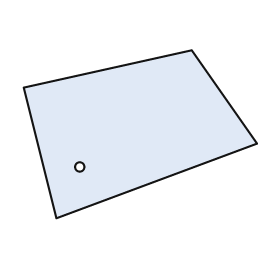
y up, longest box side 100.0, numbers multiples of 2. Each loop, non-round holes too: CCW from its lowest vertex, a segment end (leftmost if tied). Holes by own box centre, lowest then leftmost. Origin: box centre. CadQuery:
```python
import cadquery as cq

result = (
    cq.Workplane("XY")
    .moveTo(-36.0, -36.0)
    .lineTo(50.0, -4.0)
    .lineTo(22.0, 36.0)
    .lineTo(-50.0, 20.0)
    .close()
    .moveTo(-26.0, -14.0)
    .circle(2.0)
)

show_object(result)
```